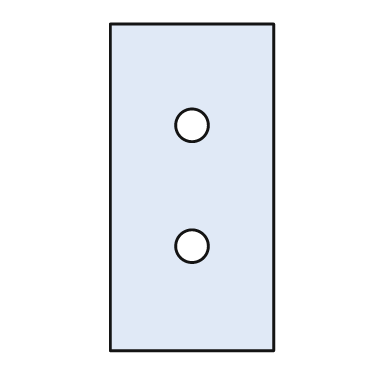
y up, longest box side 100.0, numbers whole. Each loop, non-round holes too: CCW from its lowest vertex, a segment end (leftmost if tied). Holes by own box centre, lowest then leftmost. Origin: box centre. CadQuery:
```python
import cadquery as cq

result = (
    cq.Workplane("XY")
    .moveTo(-25.0, -50.0)
    .lineTo(25.0, -50.0)
    .lineTo(25.0, 50.0)
    .lineTo(-25.0, 50.0)
    .close()
    .moveTo(0.0, -18.0)
    .circle(5.0)
    .moveTo(0.0, 19.0)
    .circle(5.0)
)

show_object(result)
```